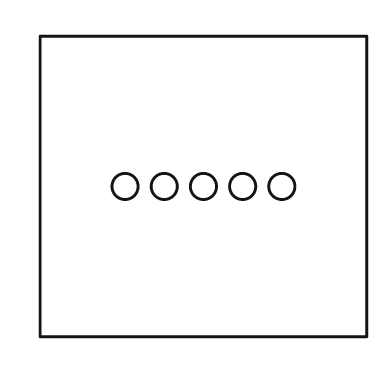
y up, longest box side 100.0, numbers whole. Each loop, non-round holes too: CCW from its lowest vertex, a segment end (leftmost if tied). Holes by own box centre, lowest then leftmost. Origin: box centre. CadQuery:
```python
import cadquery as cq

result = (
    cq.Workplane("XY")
    .moveTo(-50.0, -46.0)
    .lineTo(50.0, -46.0)
    .lineTo(50.0, 46.0)
    .lineTo(-50.0, 46.0)
    .close()
    .moveTo(-24.0, 0.0)
    .circle(4.0)
    .moveTo(-12.0, 0.0)
    .circle(4.0)
    .moveTo(0.0, 0.0)
    .circle(4.0)
    .moveTo(12.0, 0.0)
    .circle(4.0)
    .moveTo(24.0, 0.0)
    .circle(4.0)
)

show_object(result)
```